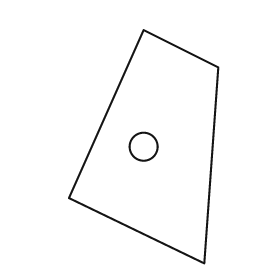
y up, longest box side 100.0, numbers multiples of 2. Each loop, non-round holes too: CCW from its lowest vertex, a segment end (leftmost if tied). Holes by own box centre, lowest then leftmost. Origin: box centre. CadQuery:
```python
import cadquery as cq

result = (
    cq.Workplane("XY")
    .moveTo(26.0, -50.0)
    .lineTo(32.0, 34.0)
    .lineTo(0.0, 50.0)
    .lineTo(-32.0, -22.0)
    .close()
    .moveTo(0.0, 0.0)
    .circle(6.0)
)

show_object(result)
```